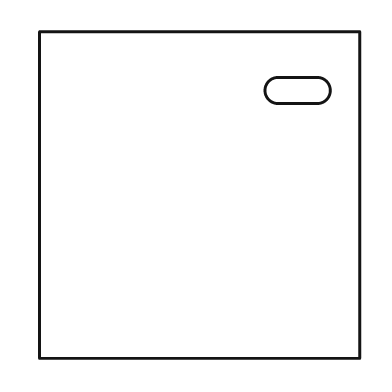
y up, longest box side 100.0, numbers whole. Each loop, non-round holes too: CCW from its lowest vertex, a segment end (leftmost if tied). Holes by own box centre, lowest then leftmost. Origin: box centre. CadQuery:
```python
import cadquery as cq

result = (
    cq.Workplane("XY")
    .moveTo(-49.0, -50.0)
    .lineTo(49.0, -50.0)
    .lineTo(49.0, 50.0)
    .lineTo(-49.0, 50.0)
    .close()
    .moveTo(24.0, 28.0)
    .lineTo(36.0, 28.0)
    .threePointArc((40.0, 32.0), (36.0, 36.0))
    .lineTo(24.0, 36.0)
    .threePointArc((20.0, 32.0), (24.0, 28.0))
    .close()
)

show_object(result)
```